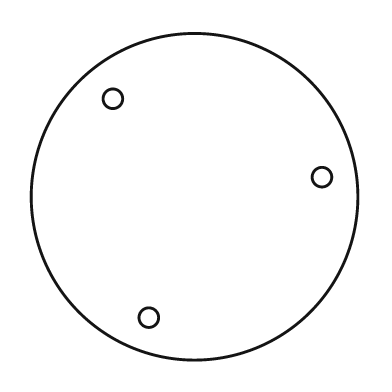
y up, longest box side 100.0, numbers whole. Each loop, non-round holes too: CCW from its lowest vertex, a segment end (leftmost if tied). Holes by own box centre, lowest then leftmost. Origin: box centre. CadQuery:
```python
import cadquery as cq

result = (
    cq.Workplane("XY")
    .moveTo(0.0, 0.0)
    .circle(50.0)
    .moveTo(-14.0, -37.0)
    .circle(3.0)
    .moveTo(39.0, 6.0)
    .circle(3.0)
    .moveTo(-25.0, 30.0)
    .circle(3.0)
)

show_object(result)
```